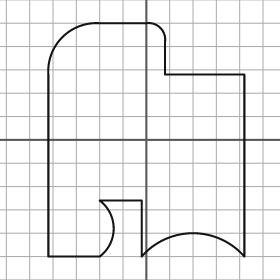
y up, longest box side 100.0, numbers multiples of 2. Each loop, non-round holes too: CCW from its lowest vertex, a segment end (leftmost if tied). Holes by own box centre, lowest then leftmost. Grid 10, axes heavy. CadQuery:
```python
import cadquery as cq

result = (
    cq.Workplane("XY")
    .moveTo(-42.0, -50.0)
    .lineTo(-20.0, -50.0)
    .threePointArc((-14.0, -38.0), (-20.0, -26.0))
    .lineTo(-2.0, -26.0)
    .lineTo(-2.0, -50.0)
    .threePointArc((20.0, -40.0), (42.0, -50.0))
    .lineTo(42.0, 28.0)
    .lineTo(8.0, 28.0)
    .lineTo(8.0, 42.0)
    .threePointArc((6.0, 48.0), (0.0, 50.0))
    .lineTo(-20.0, 50.0)
    .threePointArc((-36.0, 44.0), (-42.0, 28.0))
    .close()
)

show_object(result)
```